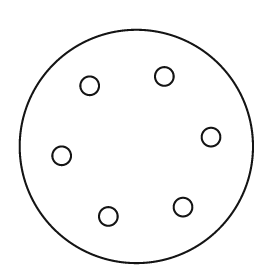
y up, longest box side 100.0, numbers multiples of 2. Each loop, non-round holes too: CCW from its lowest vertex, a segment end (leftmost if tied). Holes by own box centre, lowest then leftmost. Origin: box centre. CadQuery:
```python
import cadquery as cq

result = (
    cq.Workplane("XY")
    .moveTo(0.0, 0.0)
    .circle(50.0)
    .moveTo(-12.0, -30.0)
    .circle(4.0)
    .moveTo(20.0, -26.0)
    .circle(4.0)
    .moveTo(-32.0, -4.0)
    .circle(4.0)
    .moveTo(32.0, 4.0)
    .circle(4.0)
    .moveTo(-20.0, 26.0)
    .circle(4.0)
    .moveTo(12.0, 30.0)
    .circle(4.0)
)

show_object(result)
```